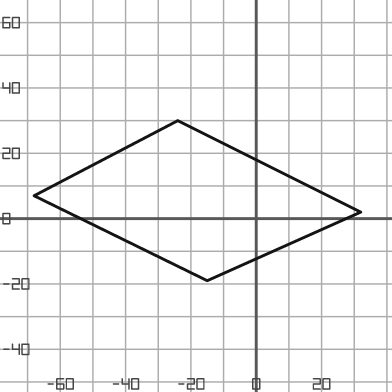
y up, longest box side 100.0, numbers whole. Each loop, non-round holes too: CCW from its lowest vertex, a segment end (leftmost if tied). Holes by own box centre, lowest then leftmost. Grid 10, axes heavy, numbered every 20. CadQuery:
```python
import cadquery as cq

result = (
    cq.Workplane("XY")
    .moveTo(-15.0, -19.0)
    .lineTo(32.0, 2.0)
    .lineTo(-24.0, 30.0)
    .lineTo(-68.0, 7.0)
    .close()
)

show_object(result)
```